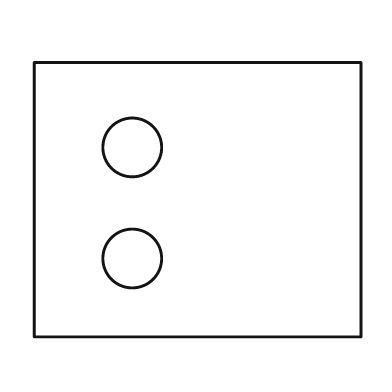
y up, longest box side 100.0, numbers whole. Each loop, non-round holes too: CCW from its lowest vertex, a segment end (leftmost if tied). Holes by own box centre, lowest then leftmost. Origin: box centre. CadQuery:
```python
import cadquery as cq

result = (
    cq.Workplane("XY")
    .moveTo(-50.0, -42.0)
    .lineTo(50.0, -42.0)
    .lineTo(50.0, 42.0)
    .lineTo(-50.0, 42.0)
    .close()
    .moveTo(-20.0, -18.0)
    .circle(9.0)
    .moveTo(-20.0, 16.0)
    .circle(9.0)
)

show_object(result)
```